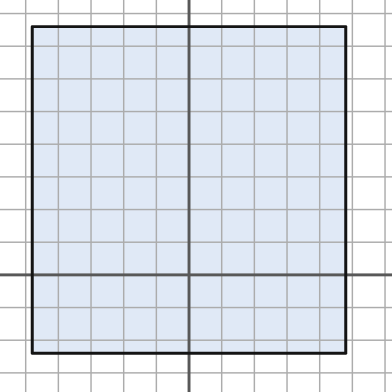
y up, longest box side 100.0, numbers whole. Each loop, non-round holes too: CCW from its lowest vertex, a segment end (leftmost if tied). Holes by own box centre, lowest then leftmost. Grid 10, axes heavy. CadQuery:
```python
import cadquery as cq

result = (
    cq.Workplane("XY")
    .moveTo(-48.0, -24.0)
    .lineTo(48.0, -24.0)
    .lineTo(48.0, 76.0)
    .lineTo(-48.0, 76.0)
    .close()
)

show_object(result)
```